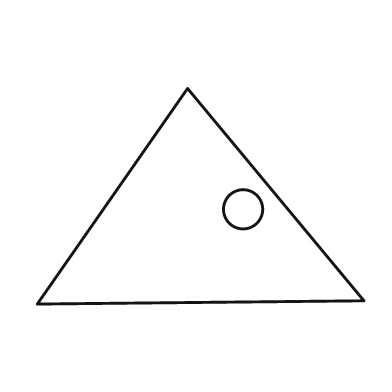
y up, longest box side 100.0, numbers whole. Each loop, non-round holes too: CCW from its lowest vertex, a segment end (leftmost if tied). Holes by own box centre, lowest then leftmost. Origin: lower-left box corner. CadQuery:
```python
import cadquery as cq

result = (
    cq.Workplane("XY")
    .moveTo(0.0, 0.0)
    .lineTo(100.0, 1.0)
    .lineTo(46.0, 66.0)
    .close()
    .moveTo(63.0, 29.0)
    .circle(6.0)
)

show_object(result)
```